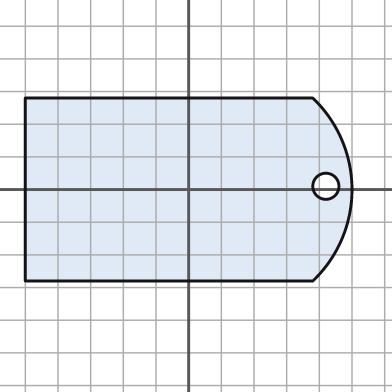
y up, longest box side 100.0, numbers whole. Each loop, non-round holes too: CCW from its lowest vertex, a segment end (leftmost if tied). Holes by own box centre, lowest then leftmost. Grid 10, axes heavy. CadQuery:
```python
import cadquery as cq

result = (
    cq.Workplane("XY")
    .moveTo(-50.0, -28.0)
    .lineTo(38.0, -28.0)
    .threePointArc((50.0, 0.0), (38.0, 28.0))
    .lineTo(-50.0, 28.0)
    .close()
    .moveTo(42.0, 1.0)
    .circle(4.0)
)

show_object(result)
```